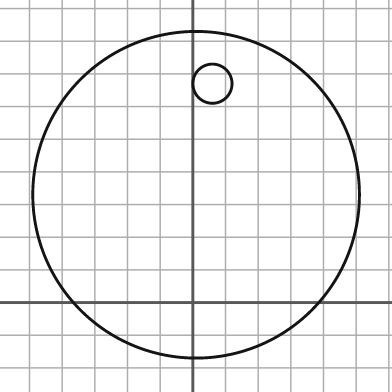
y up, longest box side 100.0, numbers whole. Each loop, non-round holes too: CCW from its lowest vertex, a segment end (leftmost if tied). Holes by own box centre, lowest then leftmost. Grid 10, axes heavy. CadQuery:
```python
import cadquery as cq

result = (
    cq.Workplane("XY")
    .moveTo(1.0, 33.0)
    .circle(50.0)
    .moveTo(6.0, 67.0)
    .circle(6.0)
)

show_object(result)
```